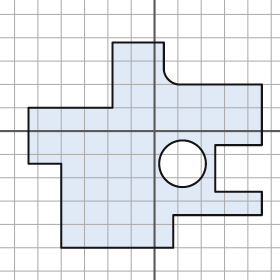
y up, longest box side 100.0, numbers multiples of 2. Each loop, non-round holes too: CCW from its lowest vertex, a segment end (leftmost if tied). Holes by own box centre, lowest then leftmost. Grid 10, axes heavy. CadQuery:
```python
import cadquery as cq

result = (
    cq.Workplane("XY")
    .moveTo(-40.0, -50.0)
    .lineTo(8.0, -50.0)
    .lineTo(8.0, -36.0)
    .lineTo(46.0, -36.0)
    .lineTo(46.0, -26.0)
    .lineTo(26.0, -26.0)
    .lineTo(26.0, -6.0)
    .lineTo(46.0, -6.0)
    .lineTo(46.0, 20.0)
    .lineTo(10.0, 20.0)
    .threePointArc((6.0, 22.0), (4.0, 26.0))
    .lineTo(4.0, 38.0)
    .lineTo(-18.0, 38.0)
    .lineTo(-18.0, 10.0)
    .lineTo(-54.0, 10.0)
    .lineTo(-54.0, -14.0)
    .lineTo(-40.0, -14.0)
    .close()
    .moveTo(12.0, -14.0)
    .circle(10.0)
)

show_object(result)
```